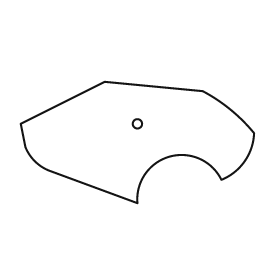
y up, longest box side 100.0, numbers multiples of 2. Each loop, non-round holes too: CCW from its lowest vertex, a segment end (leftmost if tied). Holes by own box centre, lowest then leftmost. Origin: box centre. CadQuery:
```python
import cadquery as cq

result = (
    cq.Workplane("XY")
    .moveTo(0.0, -26.0)
    .threePointArc((14.0, -6.0), (36.0, -16.0))
    .threePointArc((46.0, -8.0), (50.0, 4.0))
    .threePointArc((40.0, 14.0), (28.0, 22.0))
    .lineTo(-14.0, 26.0)
    .lineTo(-50.0, 8.0)
    .lineTo(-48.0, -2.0)
    .threePointArc((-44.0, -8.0), (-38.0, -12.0))
    .close()
    .moveTo(0.0, 8.0)
    .circle(2.0)
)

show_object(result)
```